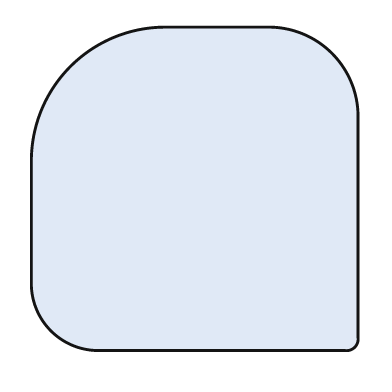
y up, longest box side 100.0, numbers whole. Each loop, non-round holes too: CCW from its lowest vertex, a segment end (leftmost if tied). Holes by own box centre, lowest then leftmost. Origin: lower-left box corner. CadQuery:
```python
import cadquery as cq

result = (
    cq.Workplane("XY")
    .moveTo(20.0, 0.0)
    .lineTo(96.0, 0.0)
    .threePointArc((99.0, 1.0), (100.0, 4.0))
    .lineTo(100.0, 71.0)
    .threePointArc((92.0, 91.0), (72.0, 99.0))
    .lineTo(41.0, 99.0)
    .threePointArc((12.0, 87.0), (0.0, 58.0))
    .lineTo(0.0, 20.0)
    .threePointArc((6.0, 6.0), (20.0, 0.0))
    .close()
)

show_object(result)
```